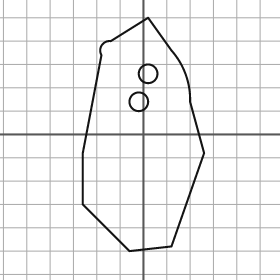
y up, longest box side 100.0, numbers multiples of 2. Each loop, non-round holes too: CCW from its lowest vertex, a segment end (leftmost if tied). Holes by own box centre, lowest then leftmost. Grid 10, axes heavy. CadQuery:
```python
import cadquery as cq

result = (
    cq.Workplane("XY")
    .moveTo(-6.0, -50.0)
    .lineTo(12.0, -48.0)
    .lineTo(26.0, -8.0)
    .lineTo(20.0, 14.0)
    .threePointArc((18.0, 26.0), (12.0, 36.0))
    .lineTo(2.0, 50.0)
    .lineTo(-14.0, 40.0)
    .threePointArc((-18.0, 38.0), (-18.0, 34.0))
    .lineTo(-26.0, -8.0)
    .lineTo(-26.0, -30.0)
    .close()
    .moveTo(-2.0, 14.0)
    .circle(4.0)
    .moveTo(2.0, 26.0)
    .circle(4.0)
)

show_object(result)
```